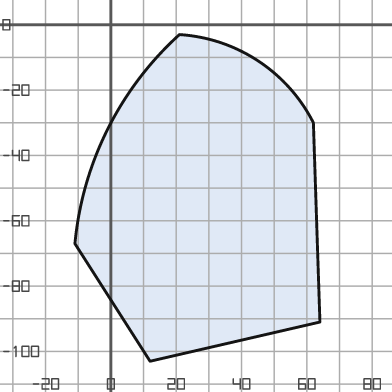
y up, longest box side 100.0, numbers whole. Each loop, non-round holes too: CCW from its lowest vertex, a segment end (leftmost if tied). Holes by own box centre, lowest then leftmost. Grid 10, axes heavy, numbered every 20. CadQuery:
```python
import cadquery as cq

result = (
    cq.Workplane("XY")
    .moveTo(12.0, -103.0)
    .lineTo(64.0, -91.0)
    .lineTo(62.0, -30.0)
    .threePointArc((45.0, -11.0), (21.0, -3.0))
    .threePointArc((-1.0, -32.0), (-11.0, -67.0))
    .close()
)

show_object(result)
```